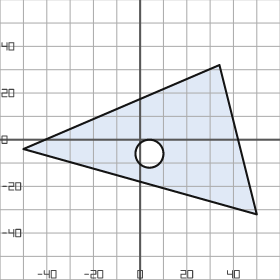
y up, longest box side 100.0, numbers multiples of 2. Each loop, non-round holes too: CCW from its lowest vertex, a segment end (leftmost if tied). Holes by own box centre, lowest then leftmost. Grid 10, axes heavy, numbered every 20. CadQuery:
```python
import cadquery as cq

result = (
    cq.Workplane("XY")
    .moveTo(50.0, -32.0)
    .lineTo(34.0, 32.0)
    .lineTo(-50.0, -4.0)
    .close()
    .moveTo(4.0, -6.0)
    .circle(6.0)
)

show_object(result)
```